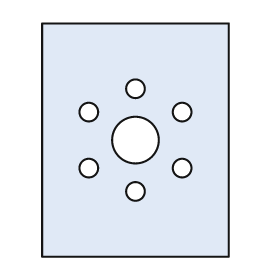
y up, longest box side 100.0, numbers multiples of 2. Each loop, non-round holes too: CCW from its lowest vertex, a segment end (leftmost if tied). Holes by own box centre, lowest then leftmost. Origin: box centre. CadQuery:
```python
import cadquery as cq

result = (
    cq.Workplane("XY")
    .moveTo(-40.0, -50.0)
    .lineTo(40.0, -50.0)
    .lineTo(40.0, 50.0)
    .lineTo(-40.0, 50.0)
    .close()
    .moveTo(0.0, -22.0)
    .circle(4.0)
    .moveTo(-20.0, -12.0)
    .circle(4.0)
    .moveTo(20.0, -12.0)
    .circle(4.0)
    .moveTo(0.0, 0.0)
    .circle(10.0)
    .moveTo(-20.0, 12.0)
    .circle(4.0)
    .moveTo(20.0, 12.0)
    .circle(4.0)
    .moveTo(0.0, 22.0)
    .circle(4.0)
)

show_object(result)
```